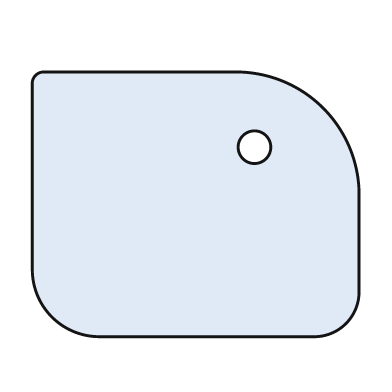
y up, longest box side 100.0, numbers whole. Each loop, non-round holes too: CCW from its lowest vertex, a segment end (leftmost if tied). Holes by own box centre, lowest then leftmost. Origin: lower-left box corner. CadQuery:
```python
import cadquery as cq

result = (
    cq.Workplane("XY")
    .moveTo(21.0, 0.0)
    .lineTo(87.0, 0.0)
    .threePointArc((96.0, 4.0), (100.0, 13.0))
    .lineTo(100.0, 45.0)
    .threePointArc((89.0, 70.0), (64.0, 81.0))
    .lineTo(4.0, 81.0)
    .threePointArc((1.0, 80.0), (0.0, 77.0))
    .lineTo(0.0, 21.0)
    .threePointArc((6.0, 6.0), (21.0, 0.0))
    .close()
    .moveTo(68.0, 58.0)
    .circle(5.0)
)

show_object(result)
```